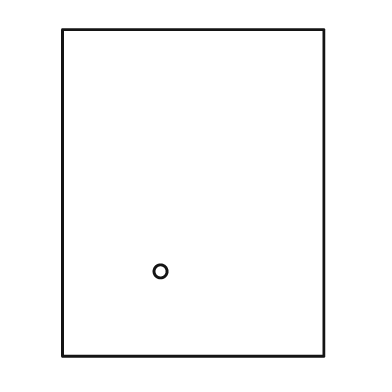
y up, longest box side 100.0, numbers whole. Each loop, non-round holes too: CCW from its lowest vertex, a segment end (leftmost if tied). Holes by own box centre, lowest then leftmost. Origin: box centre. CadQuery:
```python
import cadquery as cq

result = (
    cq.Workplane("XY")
    .moveTo(-40.0, -50.0)
    .lineTo(40.0, -50.0)
    .lineTo(40.0, 50.0)
    .lineTo(-40.0, 50.0)
    .close()
    .moveTo(-10.0, -24.0)
    .circle(2.0)
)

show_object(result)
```